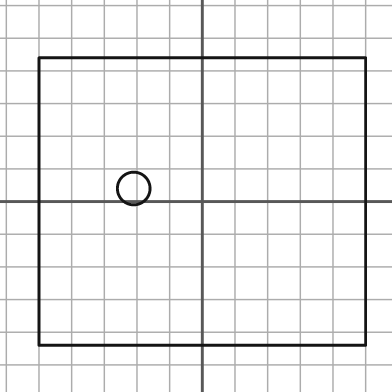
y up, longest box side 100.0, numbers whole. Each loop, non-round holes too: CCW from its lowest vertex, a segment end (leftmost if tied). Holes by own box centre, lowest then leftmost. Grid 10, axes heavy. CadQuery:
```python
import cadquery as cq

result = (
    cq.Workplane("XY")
    .moveTo(-50.0, -44.0)
    .lineTo(50.0, -44.0)
    .lineTo(50.0, 44.0)
    .lineTo(-50.0, 44.0)
    .close()
    .moveTo(-21.0, 4.0)
    .circle(5.0)
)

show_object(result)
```